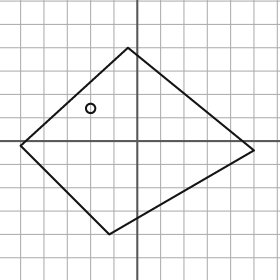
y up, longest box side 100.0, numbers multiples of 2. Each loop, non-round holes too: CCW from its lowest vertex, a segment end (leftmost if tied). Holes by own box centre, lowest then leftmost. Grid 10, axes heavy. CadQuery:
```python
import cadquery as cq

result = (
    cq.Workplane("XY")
    .moveTo(-12.0, -40.0)
    .lineTo(50.0, -4.0)
    .lineTo(-4.0, 40.0)
    .lineTo(-50.0, -2.0)
    .close()
    .moveTo(-20.0, 14.0)
    .circle(2.0)
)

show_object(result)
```